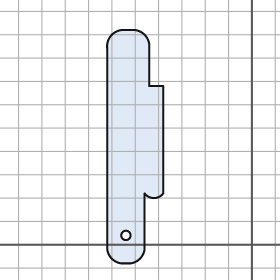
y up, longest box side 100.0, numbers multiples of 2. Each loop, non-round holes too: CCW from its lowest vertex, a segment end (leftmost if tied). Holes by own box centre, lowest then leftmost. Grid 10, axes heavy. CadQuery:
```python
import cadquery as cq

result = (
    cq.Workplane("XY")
    .moveTo(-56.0, -8.0)
    .lineTo(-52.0, -8.0)
    .threePointArc((-48.0, -6.0), (-46.0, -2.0))
    .lineTo(-46.0, 22.0)
    .threePointArc((-42.0, 20.0), (-38.0, 22.0))
    .lineTo(-38.0, 68.0)
    .lineTo(-44.0, 68.0)
    .lineTo(-44.0, 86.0)
    .threePointArc((-46.0, 90.0), (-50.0, 92.0))
    .lineTo(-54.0, 92.0)
    .threePointArc((-60.0, 90.0), (-62.0, 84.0))
    .lineTo(-62.0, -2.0)
    .threePointArc((-60.0, -6.0), (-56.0, -8.0))
    .close()
    .moveTo(-54.0, 4.0)
    .circle(2.0)
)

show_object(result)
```